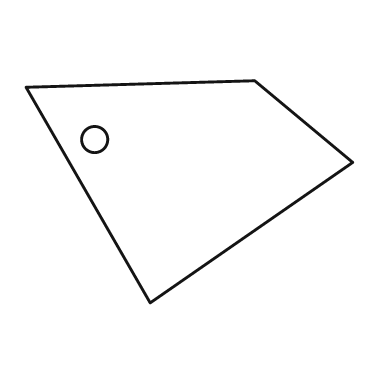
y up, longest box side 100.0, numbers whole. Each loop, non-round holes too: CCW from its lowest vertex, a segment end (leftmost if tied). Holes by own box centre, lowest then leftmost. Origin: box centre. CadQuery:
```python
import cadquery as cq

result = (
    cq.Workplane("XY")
    .moveTo(-12.0, -34.0)
    .lineTo(50.0, 9.0)
    .lineTo(20.0, 34.0)
    .lineTo(-50.0, 32.0)
    .close()
    .moveTo(-29.0, 16.0)
    .circle(4.0)
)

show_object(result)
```